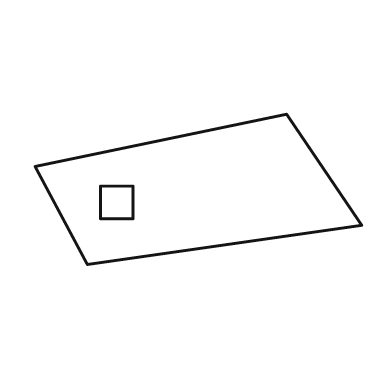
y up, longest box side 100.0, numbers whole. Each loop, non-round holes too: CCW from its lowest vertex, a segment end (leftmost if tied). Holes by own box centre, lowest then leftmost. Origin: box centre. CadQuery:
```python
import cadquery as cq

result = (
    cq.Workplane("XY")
    .moveTo(-34.0, -23.0)
    .lineTo(50.0, -11.0)
    .lineTo(27.0, 23.0)
    .lineTo(-50.0, 7.0)
    .close()
    .moveTo(-30.0, -9.0)
    .lineTo(-20.0, -9.0)
    .lineTo(-20.0, 1.0)
    .lineTo(-30.0, 1.0)
    .close()
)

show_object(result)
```